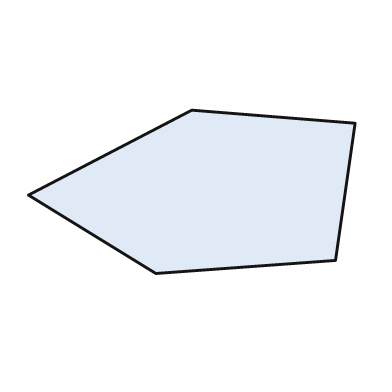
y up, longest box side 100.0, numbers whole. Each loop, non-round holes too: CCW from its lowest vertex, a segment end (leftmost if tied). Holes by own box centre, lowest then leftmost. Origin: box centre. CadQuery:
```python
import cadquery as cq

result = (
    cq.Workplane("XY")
    .moveTo(-11.0, -25.0)
    .lineTo(44.0, -21.0)
    .lineTo(50.0, 21.0)
    .lineTo(0.0, 25.0)
    .lineTo(-50.0, -1.0)
    .close()
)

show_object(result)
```